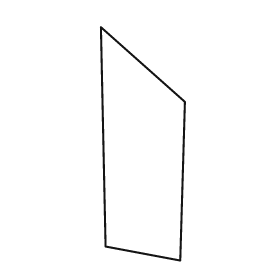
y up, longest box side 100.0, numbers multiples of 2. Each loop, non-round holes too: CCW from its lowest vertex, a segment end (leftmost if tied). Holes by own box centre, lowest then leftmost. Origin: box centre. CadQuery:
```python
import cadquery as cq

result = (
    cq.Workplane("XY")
    .moveTo(16.0, -50.0)
    .lineTo(18.0, 18.0)
    .lineTo(-18.0, 50.0)
    .lineTo(-16.0, -44.0)
    .close()
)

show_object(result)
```